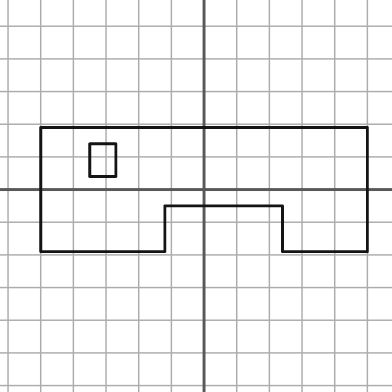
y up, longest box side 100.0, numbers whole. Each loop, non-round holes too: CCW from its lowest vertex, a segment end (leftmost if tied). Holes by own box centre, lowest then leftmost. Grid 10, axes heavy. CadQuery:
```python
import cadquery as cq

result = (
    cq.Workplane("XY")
    .moveTo(-50.0, -19.0)
    .lineTo(-12.0, -19.0)
    .lineTo(-12.0, -5.0)
    .lineTo(24.0, -5.0)
    .lineTo(24.0, -19.0)
    .lineTo(50.0, -19.0)
    .lineTo(50.0, 19.0)
    .lineTo(-50.0, 19.0)
    .close()
    .moveTo(-35.0, 4.0)
    .lineTo(-27.0, 4.0)
    .lineTo(-27.0, 14.0)
    .lineTo(-35.0, 14.0)
    .close()
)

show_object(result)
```